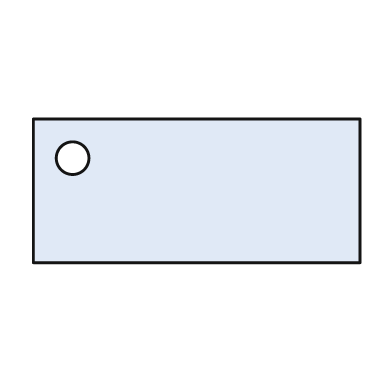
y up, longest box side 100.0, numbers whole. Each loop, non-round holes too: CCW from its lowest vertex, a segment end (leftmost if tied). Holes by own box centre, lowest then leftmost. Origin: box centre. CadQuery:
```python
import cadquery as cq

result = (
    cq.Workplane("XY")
    .moveTo(-50.0, -22.0)
    .lineTo(50.0, -22.0)
    .lineTo(50.0, 22.0)
    .lineTo(-50.0, 22.0)
    .close()
    .moveTo(-38.0, 10.0)
    .circle(5.0)
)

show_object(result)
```